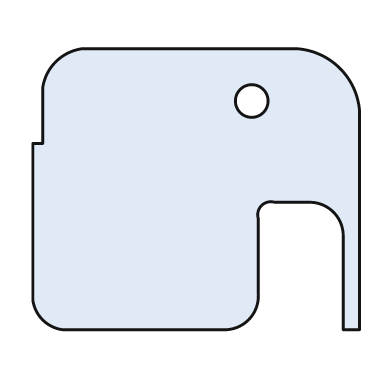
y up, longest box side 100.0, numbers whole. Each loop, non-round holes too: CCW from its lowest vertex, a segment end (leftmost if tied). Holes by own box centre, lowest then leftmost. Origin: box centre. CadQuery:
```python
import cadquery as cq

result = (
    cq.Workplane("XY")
    .moveTo(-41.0, -43.0)
    .lineTo(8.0, -43.0)
    .threePointArc((16.0, -40.0), (19.0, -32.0))
    .lineTo(19.0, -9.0)
    .threePointArc((20.0, -5.0), (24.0, -4.0))
    .lineTo(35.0, -4.0)
    .threePointArc((42.0, -7.0), (45.0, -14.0))
    .lineTo(45.0, -43.0)
    .lineTo(50.0, -43.0)
    .lineTo(50.0, 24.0)
    .threePointArc((44.0, 37.0), (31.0, 43.0))
    .lineTo(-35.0, 43.0)
    .threePointArc((-43.0, 39.0), (-47.0, 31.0))
    .lineTo(-47.0, 14.0)
    .lineTo(-50.0, 14.0)
    .lineTo(-50.0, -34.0)
    .threePointArc((-47.0, -40.0), (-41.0, -43.0))
    .close()
    .moveTo(17.0, 27.0)
    .circle(5.0)
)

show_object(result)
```